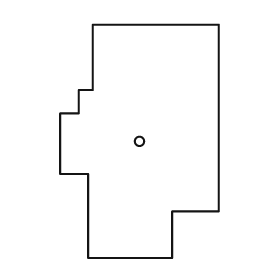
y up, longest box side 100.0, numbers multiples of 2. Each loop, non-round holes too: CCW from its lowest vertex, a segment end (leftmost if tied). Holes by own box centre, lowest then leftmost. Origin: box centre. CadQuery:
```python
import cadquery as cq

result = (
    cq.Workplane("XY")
    .moveTo(-22.0, -50.0)
    .lineTo(14.0, -50.0)
    .lineTo(14.0, -30.0)
    .lineTo(34.0, -30.0)
    .lineTo(34.0, 50.0)
    .lineTo(-20.0, 50.0)
    .lineTo(-20.0, 22.0)
    .lineTo(-26.0, 22.0)
    .lineTo(-26.0, 12.0)
    .lineTo(-34.0, 12.0)
    .lineTo(-34.0, -14.0)
    .lineTo(-22.0, -14.0)
    .close()
    .moveTo(0.0, 0.0)
    .circle(2.0)
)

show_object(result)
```